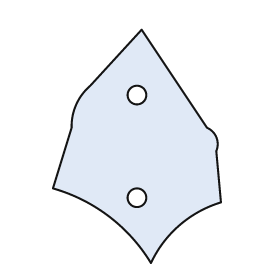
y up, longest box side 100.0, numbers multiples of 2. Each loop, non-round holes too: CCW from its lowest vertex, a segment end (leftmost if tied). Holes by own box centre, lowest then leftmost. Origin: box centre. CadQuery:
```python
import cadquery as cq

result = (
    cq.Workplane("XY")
    .moveTo(6.0, -50.0)
    .threePointArc((18.0, -34.0), (36.0, -24.0))
    .lineTo(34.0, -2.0)
    .threePointArc((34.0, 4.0), (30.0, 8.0))
    .lineTo(2.0, 50.0)
    .lineTo(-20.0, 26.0)
    .threePointArc((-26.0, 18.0), (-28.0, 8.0))
    .lineTo(-36.0, -18.0)
    .threePointArc((-12.0, -30.0), (6.0, -50.0))
    .close()
    .moveTo(0.0, -22.0)
    .circle(4.0)
    .moveTo(0.0, 22.0)
    .circle(4.0)
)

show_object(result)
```